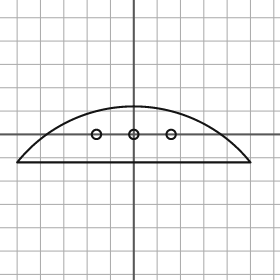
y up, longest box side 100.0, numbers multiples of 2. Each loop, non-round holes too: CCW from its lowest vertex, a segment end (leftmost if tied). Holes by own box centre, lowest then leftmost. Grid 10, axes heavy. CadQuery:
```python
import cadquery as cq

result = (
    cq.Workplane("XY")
    .moveTo(-50.0, -12.0)
    .lineTo(50.0, -12.0)
    .threePointArc((0.0, 12.0), (-50.0, -12.0))
    .close()
    .moveTo(-16.0, 0.0)
    .circle(2.0)
    .moveTo(0.0, 0.0)
    .circle(2.0)
    .moveTo(16.0, 0.0)
    .circle(2.0)
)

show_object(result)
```